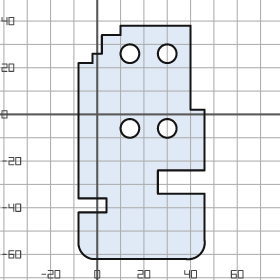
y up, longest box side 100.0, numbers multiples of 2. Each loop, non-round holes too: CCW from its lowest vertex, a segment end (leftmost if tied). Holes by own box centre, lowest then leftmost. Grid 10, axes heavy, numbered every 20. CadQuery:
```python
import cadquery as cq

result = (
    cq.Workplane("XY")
    .moveTo(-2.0, -62.0)
    .lineTo(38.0, -62.0)
    .threePointArc((44.0, -60.0), (46.0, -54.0))
    .lineTo(46.0, -34.0)
    .lineTo(26.0, -34.0)
    .lineTo(26.0, -24.0)
    .lineTo(46.0, -24.0)
    .lineTo(46.0, 2.0)
    .lineTo(40.0, 2.0)
    .lineTo(40.0, 38.0)
    .lineTo(10.0, 38.0)
    .lineTo(10.0, 34.0)
    .lineTo(2.0, 34.0)
    .lineTo(2.0, 26.0)
    .lineTo(-2.0, 26.0)
    .lineTo(-2.0, 22.0)
    .lineTo(-8.0, 22.0)
    .lineTo(-8.0, -36.0)
    .lineTo(4.0, -36.0)
    .lineTo(4.0, -42.0)
    .lineTo(-8.0, -42.0)
    .lineTo(-8.0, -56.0)
    .threePointArc((-6.0, -60.0), (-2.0, -62.0))
    .close()
    .moveTo(14.0, -6.0)
    .circle(4.0)
    .moveTo(30.0, -6.0)
    .circle(4.0)
    .moveTo(14.0, 26.0)
    .circle(4.0)
    .moveTo(30.0, 26.0)
    .circle(4.0)
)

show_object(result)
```